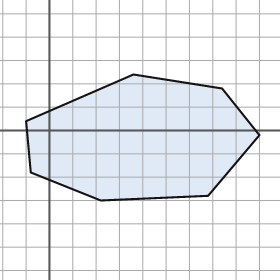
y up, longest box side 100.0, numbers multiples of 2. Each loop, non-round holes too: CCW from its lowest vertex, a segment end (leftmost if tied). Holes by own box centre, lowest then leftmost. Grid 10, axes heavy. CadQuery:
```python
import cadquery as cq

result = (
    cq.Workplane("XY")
    .moveTo(22.0, -30.0)
    .lineTo(68.0, -28.0)
    .lineTo(90.0, -2.0)
    .lineTo(74.0, 18.0)
    .lineTo(36.0, 24.0)
    .lineTo(-10.0, 4.0)
    .lineTo(-8.0, -18.0)
    .close()
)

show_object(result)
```